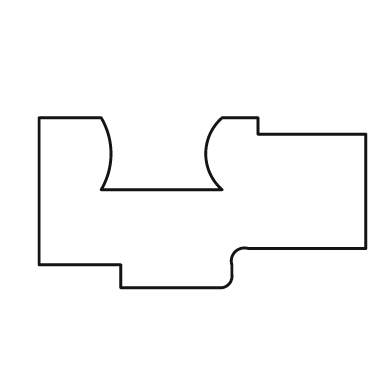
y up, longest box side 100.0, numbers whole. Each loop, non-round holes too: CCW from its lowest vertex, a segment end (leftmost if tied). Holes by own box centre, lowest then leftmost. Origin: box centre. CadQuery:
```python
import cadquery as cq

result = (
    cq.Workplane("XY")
    .moveTo(-25.0, -26.0)
    .lineTo(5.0, -26.0)
    .threePointArc((8.0, -25.0), (9.0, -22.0))
    .lineTo(9.0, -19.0)
    .threePointArc((10.0, -15.0), (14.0, -14.0))
    .lineTo(50.0, -14.0)
    .lineTo(50.0, 21.0)
    .lineTo(17.0, 21.0)
    .lineTo(17.0, 26.0)
    .lineTo(6.0, 26.0)
    .threePointArc((1.0, 15.0), (6.0, 4.0))
    .lineTo(-31.0, 4.0)
    .threePointArc((-28.0, 15.0), (-31.0, 26.0))
    .lineTo(-50.0, 26.0)
    .lineTo(-50.0, -19.0)
    .lineTo(-25.0, -19.0)
    .close()
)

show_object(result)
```